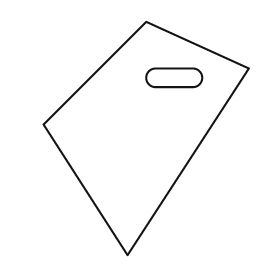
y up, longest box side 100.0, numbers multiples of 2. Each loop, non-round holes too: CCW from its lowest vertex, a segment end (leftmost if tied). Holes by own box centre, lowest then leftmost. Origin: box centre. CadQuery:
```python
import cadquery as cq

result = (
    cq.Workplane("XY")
    .moveTo(-8.0, -50.0)
    .lineTo(44.0, 30.0)
    .lineTo(0.0, 50.0)
    .lineTo(-44.0, 6.0)
    .close()
    .moveTo(4.0, 22.0)
    .lineTo(20.0, 22.0)
    .threePointArc((24.0, 26.0), (20.0, 30.0))
    .lineTo(4.0, 30.0)
    .threePointArc((0.0, 26.0), (4.0, 22.0))
    .close()
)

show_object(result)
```